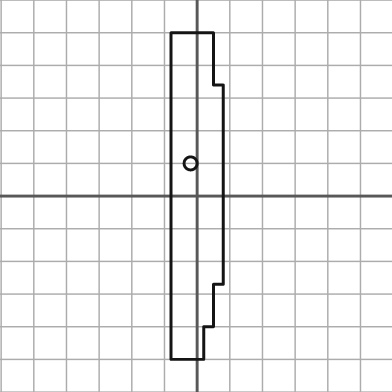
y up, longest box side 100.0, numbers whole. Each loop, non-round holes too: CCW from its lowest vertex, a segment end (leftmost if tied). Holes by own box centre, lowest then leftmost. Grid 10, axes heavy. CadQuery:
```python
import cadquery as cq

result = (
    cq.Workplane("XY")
    .moveTo(-8.0, -50.0)
    .lineTo(2.0, -50.0)
    .lineTo(2.0, -40.0)
    .lineTo(5.0, -40.0)
    .lineTo(5.0, -27.0)
    .lineTo(8.0, -27.0)
    .lineTo(8.0, 34.0)
    .lineTo(5.0, 34.0)
    .lineTo(5.0, 50.0)
    .lineTo(-8.0, 50.0)
    .close()
    .moveTo(-2.0, 10.0)
    .circle(2.0)
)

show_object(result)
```